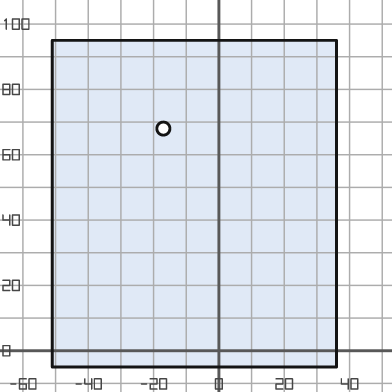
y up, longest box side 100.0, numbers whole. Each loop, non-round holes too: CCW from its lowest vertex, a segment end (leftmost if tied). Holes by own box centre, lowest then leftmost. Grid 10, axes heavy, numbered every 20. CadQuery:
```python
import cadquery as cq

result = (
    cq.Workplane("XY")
    .moveTo(-51.0, -5.0)
    .lineTo(36.0, -5.0)
    .lineTo(36.0, 95.0)
    .lineTo(-51.0, 95.0)
    .close()
    .moveTo(-17.0, 68.0)
    .circle(2.0)
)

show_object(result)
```